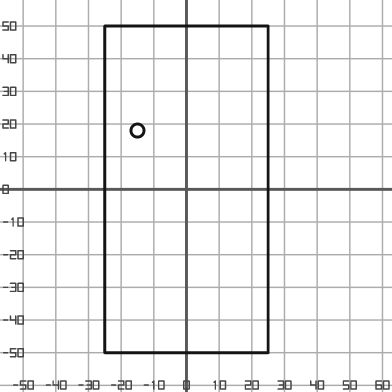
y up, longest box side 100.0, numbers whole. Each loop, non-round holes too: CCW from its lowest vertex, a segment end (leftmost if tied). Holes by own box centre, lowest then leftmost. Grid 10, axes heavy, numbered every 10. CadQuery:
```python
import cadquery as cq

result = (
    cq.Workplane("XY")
    .moveTo(-25.0, -50.0)
    .lineTo(25.0, -50.0)
    .lineTo(25.0, 50.0)
    .lineTo(-25.0, 50.0)
    .close()
    .moveTo(-15.0, 18.0)
    .circle(2.0)
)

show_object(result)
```